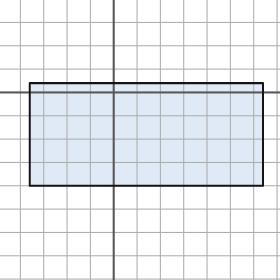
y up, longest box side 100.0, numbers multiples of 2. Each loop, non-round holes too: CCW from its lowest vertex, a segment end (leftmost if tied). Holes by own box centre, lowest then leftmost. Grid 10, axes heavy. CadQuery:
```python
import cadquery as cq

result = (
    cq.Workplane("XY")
    .moveTo(-36.0, -40.0)
    .lineTo(64.0, -40.0)
    .lineTo(64.0, 4.0)
    .lineTo(-36.0, 4.0)
    .close()
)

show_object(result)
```